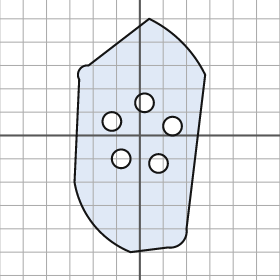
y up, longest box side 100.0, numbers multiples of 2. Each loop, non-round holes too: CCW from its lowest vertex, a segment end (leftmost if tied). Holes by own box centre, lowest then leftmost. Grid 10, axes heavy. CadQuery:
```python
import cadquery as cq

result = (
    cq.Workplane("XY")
    .moveTo(-4.0, -50.0)
    .lineTo(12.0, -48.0)
    .threePointArc((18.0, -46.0), (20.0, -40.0))
    .lineTo(28.0, 26.0)
    .threePointArc((18.0, 40.0), (4.0, 50.0))
    .lineTo(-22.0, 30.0)
    .threePointArc((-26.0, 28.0), (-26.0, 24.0))
    .lineTo(-28.0, -20.0)
    .threePointArc((-20.0, -38.0), (-4.0, -50.0))
    .close()
    .moveTo(8.0, -12.0)
    .circle(4.0)
    .moveTo(-8.0, -10.0)
    .circle(4.0)
    .moveTo(14.0, 4.0)
    .circle(4.0)
    .moveTo(-12.0, 6.0)
    .circle(4.0)
    .moveTo(2.0, 14.0)
    .circle(4.0)
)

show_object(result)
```